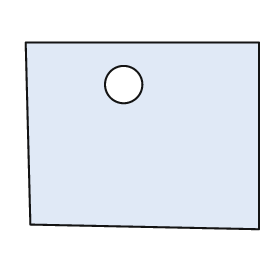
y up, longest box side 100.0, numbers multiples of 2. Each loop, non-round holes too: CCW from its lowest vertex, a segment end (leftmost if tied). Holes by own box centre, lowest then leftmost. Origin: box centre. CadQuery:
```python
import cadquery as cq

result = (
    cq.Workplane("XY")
    .moveTo(50.0, -40.0)
    .lineTo(50.0, 40.0)
    .lineTo(-50.0, 40.0)
    .lineTo(-48.0, -38.0)
    .close()
    .moveTo(-8.0, 22.0)
    .circle(8.0)
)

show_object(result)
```